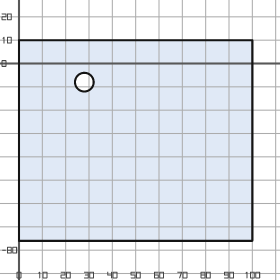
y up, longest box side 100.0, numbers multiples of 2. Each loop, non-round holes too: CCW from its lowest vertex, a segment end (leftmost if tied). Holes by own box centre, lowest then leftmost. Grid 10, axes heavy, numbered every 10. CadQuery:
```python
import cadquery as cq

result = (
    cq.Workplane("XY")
    .moveTo(0.0, -76.0)
    .lineTo(100.0, -76.0)
    .lineTo(100.0, 10.0)
    .lineTo(0.0, 10.0)
    .close()
    .moveTo(28.0, -8.0)
    .circle(4.0)
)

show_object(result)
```